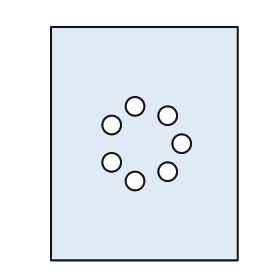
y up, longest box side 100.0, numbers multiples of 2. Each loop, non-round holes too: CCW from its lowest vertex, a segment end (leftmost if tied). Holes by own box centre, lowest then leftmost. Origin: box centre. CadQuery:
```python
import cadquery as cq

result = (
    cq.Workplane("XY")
    .moveTo(-40.0, -50.0)
    .lineTo(40.0, -50.0)
    .lineTo(40.0, 50.0)
    .lineTo(-40.0, 50.0)
    .close()
    .moveTo(-4.0, -16.0)
    .circle(4.0)
    .moveTo(10.0, -12.0)
    .circle(4.0)
    .moveTo(-14.0, -8.0)
    .circle(4.0)
    .moveTo(16.0, 0.0)
    .circle(4.0)
    .moveTo(-14.0, 8.0)
    .circle(4.0)
    .moveTo(10.0, 12.0)
    .circle(4.0)
    .moveTo(-4.0, 16.0)
    .circle(4.0)
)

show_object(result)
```